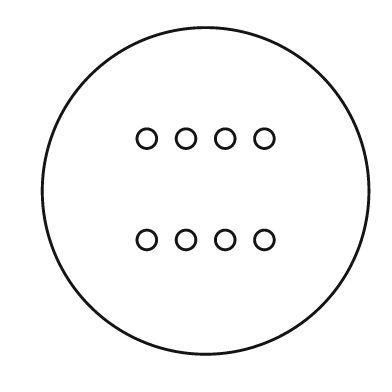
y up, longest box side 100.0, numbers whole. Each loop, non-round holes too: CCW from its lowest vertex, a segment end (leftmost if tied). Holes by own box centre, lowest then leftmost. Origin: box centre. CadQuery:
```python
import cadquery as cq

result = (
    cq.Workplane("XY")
    .moveTo(0.0, 0.0)
    .circle(50.0)
    .moveTo(-18.0, -15.0)
    .circle(3.0)
    .moveTo(-6.0, -15.0)
    .circle(3.0)
    .moveTo(6.0, -15.0)
    .circle(3.0)
    .moveTo(18.0, -15.0)
    .circle(3.0)
    .moveTo(-18.0, 16.0)
    .circle(3.0)
    .moveTo(-6.0, 16.0)
    .circle(3.0)
    .moveTo(6.0, 16.0)
    .circle(3.0)
    .moveTo(18.0, 16.0)
    .circle(3.0)
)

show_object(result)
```